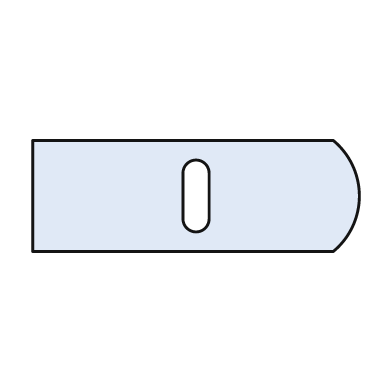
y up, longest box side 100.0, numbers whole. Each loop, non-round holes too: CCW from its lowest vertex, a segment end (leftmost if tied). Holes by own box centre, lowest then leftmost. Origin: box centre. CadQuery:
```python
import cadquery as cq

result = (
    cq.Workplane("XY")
    .moveTo(-50.0, -17.0)
    .lineTo(42.0, -17.0)
    .threePointArc((50.0, 0.0), (42.0, 17.0))
    .lineTo(-50.0, 17.0)
    .close()
    .moveTo(-4.0, -7.0)
    .threePointArc((0.0, -11.0), (4.0, -7.0))
    .lineTo(4.0, 7.0)
    .threePointArc((0.0, 11.0), (-4.0, 7.0))
    .close()
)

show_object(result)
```